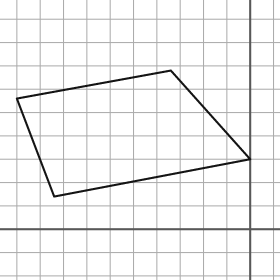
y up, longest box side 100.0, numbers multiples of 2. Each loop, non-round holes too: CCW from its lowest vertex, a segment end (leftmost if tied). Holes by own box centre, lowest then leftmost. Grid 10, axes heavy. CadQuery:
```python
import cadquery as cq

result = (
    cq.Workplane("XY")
    .moveTo(-84.0, 14.0)
    .lineTo(0.0, 30.0)
    .lineTo(-34.0, 68.0)
    .lineTo(-100.0, 56.0)
    .close()
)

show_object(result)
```